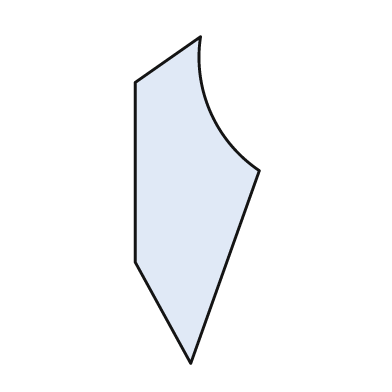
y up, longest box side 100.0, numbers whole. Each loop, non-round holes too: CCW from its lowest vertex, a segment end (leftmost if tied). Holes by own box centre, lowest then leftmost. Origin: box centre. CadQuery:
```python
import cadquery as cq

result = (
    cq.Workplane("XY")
    .moveTo(-2.0, -50.0)
    .lineTo(19.0, 9.0)
    .threePointArc((4.0, 27.0), (1.0, 50.0))
    .lineTo(-19.0, 36.0)
    .lineTo(-19.0, -19.0)
    .close()
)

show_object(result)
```